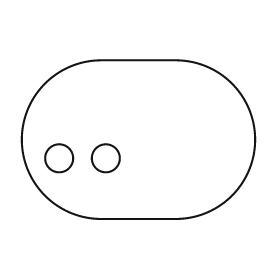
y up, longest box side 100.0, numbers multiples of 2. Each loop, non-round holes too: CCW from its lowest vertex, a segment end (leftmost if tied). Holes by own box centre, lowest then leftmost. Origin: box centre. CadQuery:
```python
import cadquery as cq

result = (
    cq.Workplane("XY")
    .moveTo(-16.0, -34.0)
    .lineTo(16.0, -34.0)
    .threePointArc((50.0, 0.0), (16.0, 34.0))
    .lineTo(-16.0, 34.0)
    .threePointArc((-50.0, 0.0), (-16.0, -34.0))
    .close()
    .moveTo(-34.0, -8.0)
    .circle(6.0)
    .moveTo(-14.0, -8.0)
    .circle(6.0)
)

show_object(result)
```